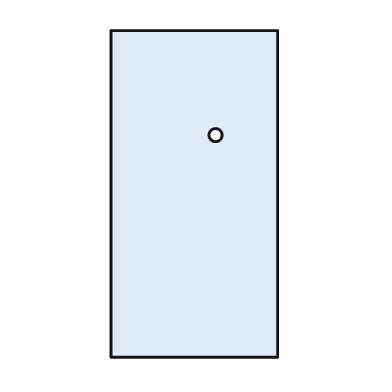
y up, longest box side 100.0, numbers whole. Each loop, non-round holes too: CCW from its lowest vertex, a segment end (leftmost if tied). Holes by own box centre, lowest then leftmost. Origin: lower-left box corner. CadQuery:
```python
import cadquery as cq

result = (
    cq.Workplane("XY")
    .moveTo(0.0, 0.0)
    .lineTo(51.0, 0.0)
    .lineTo(51.0, 100.0)
    .lineTo(0.0, 100.0)
    .close()
    .moveTo(32.0, 68.0)
    .circle(2.0)
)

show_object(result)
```